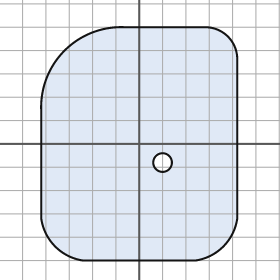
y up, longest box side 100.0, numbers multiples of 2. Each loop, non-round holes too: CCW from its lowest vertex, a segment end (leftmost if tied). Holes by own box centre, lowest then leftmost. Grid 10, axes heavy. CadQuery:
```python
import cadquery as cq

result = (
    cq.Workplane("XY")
    .moveTo(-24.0, -50.0)
    .lineTo(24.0, -50.0)
    .threePointArc((36.0, -44.0), (42.0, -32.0))
    .lineTo(42.0, 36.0)
    .threePointArc((38.0, 46.0), (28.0, 50.0))
    .lineTo(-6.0, 50.0)
    .threePointArc((-32.0, 40.0), (-42.0, 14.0))
    .lineTo(-42.0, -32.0)
    .threePointArc((-36.0, -44.0), (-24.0, -50.0))
    .close()
    .moveTo(10.0, -8.0)
    .circle(4.0)
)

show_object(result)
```